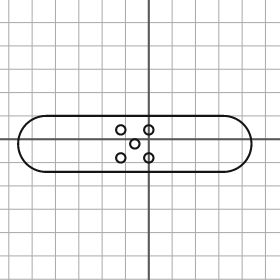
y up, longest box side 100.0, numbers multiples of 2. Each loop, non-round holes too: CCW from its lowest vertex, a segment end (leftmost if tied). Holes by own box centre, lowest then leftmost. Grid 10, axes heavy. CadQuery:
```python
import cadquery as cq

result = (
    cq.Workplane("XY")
    .moveTo(-44.0, -14.0)
    .lineTo(32.0, -14.0)
    .threePointArc((44.0, -2.0), (32.0, 10.0))
    .lineTo(-44.0, 10.0)
    .threePointArc((-56.0, -2.0), (-44.0, -14.0))
    .close()
    .moveTo(-12.0, -8.0)
    .circle(2.0)
    .moveTo(0.0, -8.0)
    .circle(2.0)
    .moveTo(-6.0, -2.0)
    .circle(2.0)
    .moveTo(-12.0, 4.0)
    .circle(2.0)
    .moveTo(0.0, 4.0)
    .circle(2.0)
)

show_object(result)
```